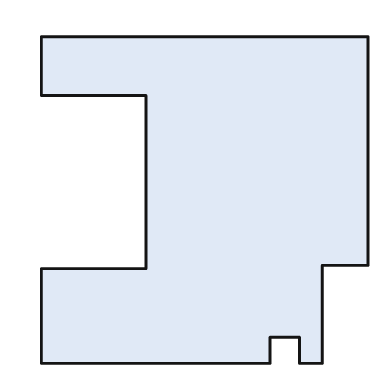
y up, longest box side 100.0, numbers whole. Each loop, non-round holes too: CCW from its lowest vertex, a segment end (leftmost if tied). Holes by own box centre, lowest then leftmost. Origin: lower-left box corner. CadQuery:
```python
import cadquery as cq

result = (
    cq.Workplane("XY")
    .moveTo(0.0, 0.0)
    .lineTo(70.0, 0.0)
    .lineTo(70.0, 8.0)
    .lineTo(79.0, 8.0)
    .lineTo(79.0, 0.0)
    .lineTo(86.0, 0.0)
    .lineTo(86.0, 30.0)
    .lineTo(100.0, 30.0)
    .lineTo(100.0, 100.0)
    .lineTo(0.0, 100.0)
    .lineTo(0.0, 82.0)
    .lineTo(32.0, 82.0)
    .lineTo(32.0, 29.0)
    .lineTo(0.0, 29.0)
    .close()
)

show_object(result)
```